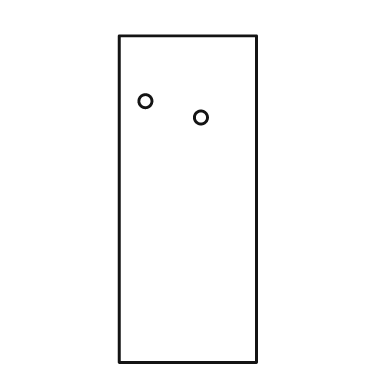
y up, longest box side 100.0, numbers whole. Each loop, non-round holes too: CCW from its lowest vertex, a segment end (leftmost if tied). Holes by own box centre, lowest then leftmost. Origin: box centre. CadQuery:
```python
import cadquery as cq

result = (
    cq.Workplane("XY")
    .moveTo(-21.0, -50.0)
    .lineTo(21.0, -50.0)
    .lineTo(21.0, 50.0)
    .lineTo(-21.0, 50.0)
    .close()
    .moveTo(4.0, 25.0)
    .circle(2.0)
    .moveTo(-13.0, 30.0)
    .circle(2.0)
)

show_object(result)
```